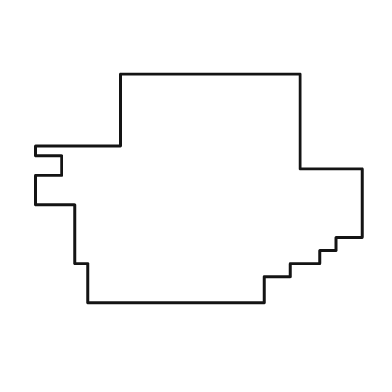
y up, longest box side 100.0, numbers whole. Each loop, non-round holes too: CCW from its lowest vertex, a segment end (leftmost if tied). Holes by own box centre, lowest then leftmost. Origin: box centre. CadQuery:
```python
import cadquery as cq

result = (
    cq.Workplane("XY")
    .moveTo(-34.0, -35.0)
    .lineTo(20.0, -35.0)
    .lineTo(20.0, -27.0)
    .lineTo(28.0, -27.0)
    .lineTo(28.0, -23.0)
    .lineTo(37.0, -23.0)
    .lineTo(37.0, -19.0)
    .lineTo(42.0, -19.0)
    .lineTo(42.0, -15.0)
    .lineTo(50.0, -15.0)
    .lineTo(50.0, 6.0)
    .lineTo(31.0, 6.0)
    .lineTo(31.0, 35.0)
    .lineTo(-24.0, 35.0)
    .lineTo(-24.0, 13.0)
    .lineTo(-50.0, 13.0)
    .lineTo(-50.0, 10.0)
    .lineTo(-42.0, 10.0)
    .lineTo(-42.0, 4.0)
    .lineTo(-50.0, 4.0)
    .lineTo(-50.0, -5.0)
    .lineTo(-38.0, -5.0)
    .lineTo(-38.0, -23.0)
    .lineTo(-34.0, -23.0)
    .close()
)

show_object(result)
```